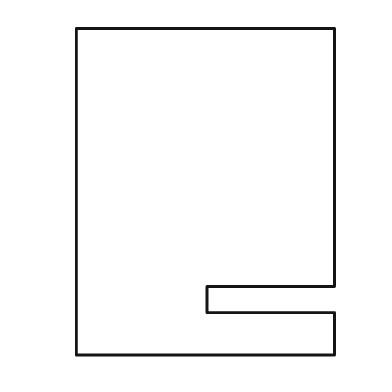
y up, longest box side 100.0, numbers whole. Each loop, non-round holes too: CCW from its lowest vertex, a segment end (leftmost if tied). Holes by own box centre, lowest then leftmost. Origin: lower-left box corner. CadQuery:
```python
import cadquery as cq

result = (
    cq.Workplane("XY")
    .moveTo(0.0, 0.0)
    .lineTo(79.0, 0.0)
    .lineTo(79.0, 13.0)
    .lineTo(40.0, 13.0)
    .lineTo(40.0, 21.0)
    .lineTo(79.0, 21.0)
    .lineTo(79.0, 100.0)
    .lineTo(0.0, 100.0)
    .close()
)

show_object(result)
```